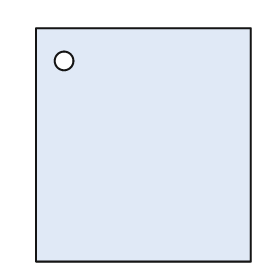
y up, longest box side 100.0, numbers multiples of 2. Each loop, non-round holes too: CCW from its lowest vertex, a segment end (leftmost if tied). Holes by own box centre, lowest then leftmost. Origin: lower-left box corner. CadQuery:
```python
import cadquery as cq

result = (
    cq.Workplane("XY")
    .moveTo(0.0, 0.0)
    .lineTo(92.0, 0.0)
    .lineTo(92.0, 100.0)
    .lineTo(0.0, 100.0)
    .close()
    .moveTo(12.0, 86.0)
    .circle(4.0)
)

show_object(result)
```